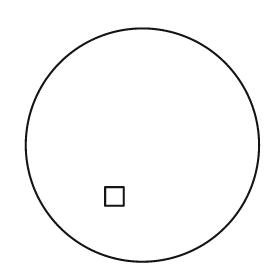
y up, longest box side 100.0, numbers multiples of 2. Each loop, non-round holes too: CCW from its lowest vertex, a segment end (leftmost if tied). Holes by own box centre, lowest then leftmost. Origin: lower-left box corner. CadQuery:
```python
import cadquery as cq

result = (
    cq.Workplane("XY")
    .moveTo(50.0, 50.0)
    .circle(50.0)
    .moveTo(34.0, 24.0)
    .lineTo(42.0, 24.0)
    .lineTo(42.0, 32.0)
    .lineTo(34.0, 32.0)
    .close()
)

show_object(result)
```